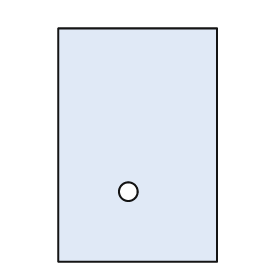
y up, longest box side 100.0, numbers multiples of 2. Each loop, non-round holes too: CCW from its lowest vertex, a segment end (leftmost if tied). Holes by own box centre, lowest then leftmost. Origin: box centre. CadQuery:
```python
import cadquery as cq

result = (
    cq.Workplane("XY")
    .moveTo(-34.0, -50.0)
    .lineTo(34.0, -50.0)
    .lineTo(34.0, 50.0)
    .lineTo(-34.0, 50.0)
    .close()
    .moveTo(-4.0, -20.0)
    .circle(4.0)
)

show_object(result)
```